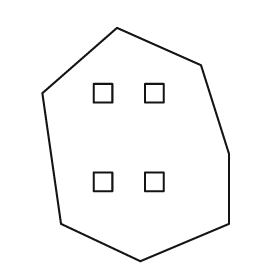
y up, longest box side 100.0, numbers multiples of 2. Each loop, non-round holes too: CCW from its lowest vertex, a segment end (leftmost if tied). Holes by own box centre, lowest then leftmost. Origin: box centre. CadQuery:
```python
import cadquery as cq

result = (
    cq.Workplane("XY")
    .moveTo(2.0, -50.0)
    .lineTo(40.0, -34.0)
    .lineTo(40.0, -4.0)
    .lineTo(28.0, 34.0)
    .lineTo(-8.0, 50.0)
    .lineTo(-40.0, 22.0)
    .lineTo(-32.0, -34.0)
    .close()
    .moveTo(-18.0, -20.0)
    .lineTo(-10.0, -20.0)
    .lineTo(-10.0, -12.0)
    .lineTo(-18.0, -12.0)
    .close()
    .moveTo(4.0, -20.0)
    .lineTo(12.0, -20.0)
    .lineTo(12.0, -12.0)
    .lineTo(4.0, -12.0)
    .close()
    .moveTo(-18.0, 18.0)
    .lineTo(-10.0, 18.0)
    .lineTo(-10.0, 26.0)
    .lineTo(-18.0, 26.0)
    .close()
    .moveTo(4.0, 18.0)
    .lineTo(12.0, 18.0)
    .lineTo(12.0, 26.0)
    .lineTo(4.0, 26.0)
    .close()
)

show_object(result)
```